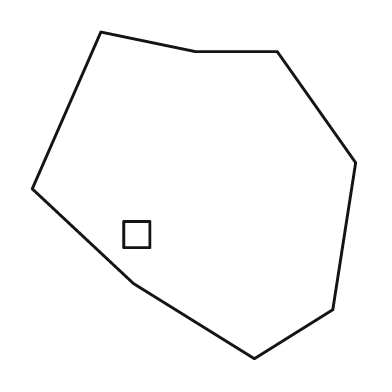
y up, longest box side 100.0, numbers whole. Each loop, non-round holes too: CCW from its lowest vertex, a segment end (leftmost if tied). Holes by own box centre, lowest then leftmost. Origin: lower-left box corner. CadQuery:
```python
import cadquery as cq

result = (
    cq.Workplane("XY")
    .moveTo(68.0, 0.0)
    .lineTo(92.0, 15.0)
    .lineTo(99.0, 60.0)
    .lineTo(75.0, 94.0)
    .lineTo(50.0, 94.0)
    .lineTo(21.0, 100.0)
    .lineTo(0.0, 52.0)
    .lineTo(31.0, 23.0)
    .close()
    .moveTo(28.0, 34.0)
    .lineTo(36.0, 34.0)
    .lineTo(36.0, 42.0)
    .lineTo(28.0, 42.0)
    .close()
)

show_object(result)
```